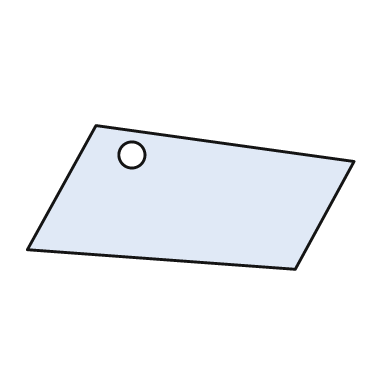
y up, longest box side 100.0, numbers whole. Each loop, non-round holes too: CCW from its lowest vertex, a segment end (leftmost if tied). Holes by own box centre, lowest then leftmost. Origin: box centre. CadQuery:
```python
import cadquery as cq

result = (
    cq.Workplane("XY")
    .moveTo(32.0, -22.0)
    .lineTo(50.0, 11.0)
    .lineTo(-29.0, 22.0)
    .lineTo(-50.0, -16.0)
    .close()
    .moveTo(-18.0, 13.0)
    .circle(4.0)
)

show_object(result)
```